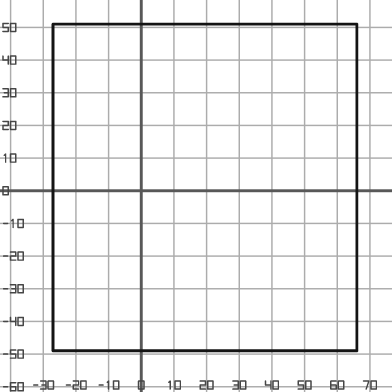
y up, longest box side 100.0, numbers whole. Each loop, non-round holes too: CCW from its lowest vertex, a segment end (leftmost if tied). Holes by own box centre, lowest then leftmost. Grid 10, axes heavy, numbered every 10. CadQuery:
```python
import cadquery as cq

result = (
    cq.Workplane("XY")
    .moveTo(-27.0, -49.0)
    .lineTo(66.0, -49.0)
    .lineTo(66.0, 51.0)
    .lineTo(-27.0, 51.0)
    .close()
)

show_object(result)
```